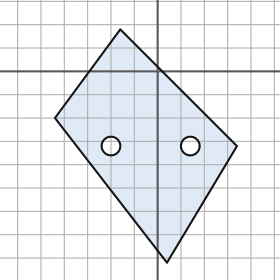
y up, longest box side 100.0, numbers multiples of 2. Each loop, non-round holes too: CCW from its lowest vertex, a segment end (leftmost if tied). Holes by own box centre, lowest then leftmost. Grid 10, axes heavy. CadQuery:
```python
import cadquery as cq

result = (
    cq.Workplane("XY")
    .moveTo(4.0, -82.0)
    .lineTo(34.0, -32.0)
    .lineTo(-16.0, 18.0)
    .lineTo(-44.0, -20.0)
    .close()
    .moveTo(-20.0, -32.0)
    .circle(4.0)
    .moveTo(14.0, -32.0)
    .circle(4.0)
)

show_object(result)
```